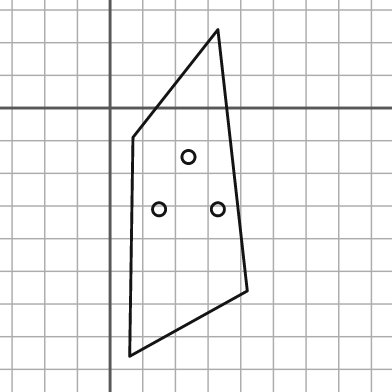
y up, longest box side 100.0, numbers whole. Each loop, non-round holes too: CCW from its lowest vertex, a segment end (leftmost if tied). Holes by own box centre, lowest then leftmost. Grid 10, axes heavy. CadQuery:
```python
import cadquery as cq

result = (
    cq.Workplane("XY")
    .moveTo(6.0, -76.0)
    .lineTo(42.0, -56.0)
    .lineTo(33.0, 24.0)
    .lineTo(7.0, -9.0)
    .close()
    .moveTo(15.0, -31.0)
    .circle(2.0)
    .moveTo(33.0, -31.0)
    .circle(2.0)
    .moveTo(24.0, -15.0)
    .circle(2.0)
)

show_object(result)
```